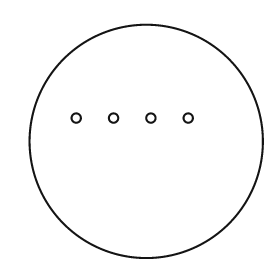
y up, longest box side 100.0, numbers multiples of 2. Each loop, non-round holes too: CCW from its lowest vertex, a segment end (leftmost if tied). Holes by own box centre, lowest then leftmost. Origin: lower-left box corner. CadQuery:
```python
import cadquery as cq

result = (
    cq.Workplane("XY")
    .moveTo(50.0, 50.0)
    .circle(50.0)
    .moveTo(20.0, 60.0)
    .circle(2.0)
    .moveTo(36.0, 60.0)
    .circle(2.0)
    .moveTo(52.0, 60.0)
    .circle(2.0)
    .moveTo(68.0, 60.0)
    .circle(2.0)
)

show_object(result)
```